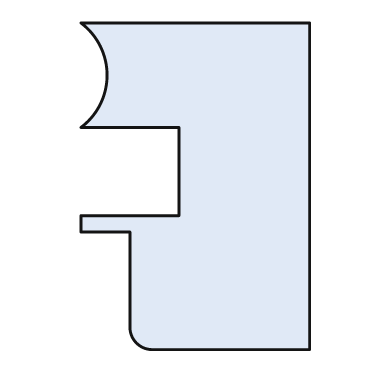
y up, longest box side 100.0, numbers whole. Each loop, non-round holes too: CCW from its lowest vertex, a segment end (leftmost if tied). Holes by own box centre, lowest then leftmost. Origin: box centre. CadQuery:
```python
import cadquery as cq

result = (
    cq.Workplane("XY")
    .moveTo(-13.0, -50.0)
    .lineTo(35.0, -50.0)
    .lineTo(35.0, 50.0)
    .lineTo(-35.0, 50.0)
    .threePointArc((-27.0, 34.0), (-35.0, 18.0))
    .lineTo(-5.0, 18.0)
    .lineTo(-5.0, -9.0)
    .lineTo(-35.0, -9.0)
    .lineTo(-35.0, -14.0)
    .lineTo(-20.0, -14.0)
    .lineTo(-20.0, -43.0)
    .threePointArc((-18.0, -48.0), (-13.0, -50.0))
    .close()
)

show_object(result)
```